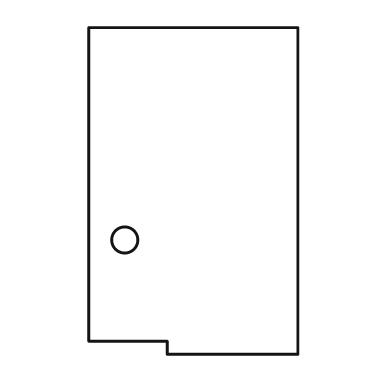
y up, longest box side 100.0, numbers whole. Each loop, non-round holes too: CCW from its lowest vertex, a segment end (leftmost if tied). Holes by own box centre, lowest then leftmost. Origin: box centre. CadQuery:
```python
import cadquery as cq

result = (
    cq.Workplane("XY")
    .moveTo(-8.0, -50.0)
    .lineTo(32.0, -50.0)
    .lineTo(32.0, 50.0)
    .lineTo(-32.0, 50.0)
    .lineTo(-32.0, -46.0)
    .lineTo(-8.0, -46.0)
    .close()
    .moveTo(-21.0, -15.0)
    .circle(4.0)
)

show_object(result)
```